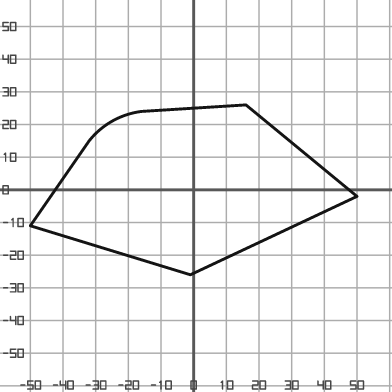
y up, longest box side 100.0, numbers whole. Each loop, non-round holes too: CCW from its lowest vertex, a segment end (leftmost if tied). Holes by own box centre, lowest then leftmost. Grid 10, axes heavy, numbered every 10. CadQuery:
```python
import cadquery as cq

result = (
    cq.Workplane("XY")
    .moveTo(-1.0, -26.0)
    .lineTo(50.0, -2.0)
    .lineTo(16.0, 26.0)
    .lineTo(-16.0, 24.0)
    .threePointArc((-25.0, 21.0), (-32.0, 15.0))
    .lineTo(-50.0, -11.0)
    .close()
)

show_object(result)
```